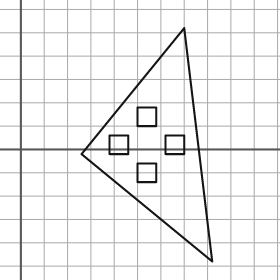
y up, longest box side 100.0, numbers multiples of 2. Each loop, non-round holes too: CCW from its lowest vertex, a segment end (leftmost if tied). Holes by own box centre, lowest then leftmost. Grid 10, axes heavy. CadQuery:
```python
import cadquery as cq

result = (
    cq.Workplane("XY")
    .moveTo(82.0, -48.0)
    .lineTo(70.0, 52.0)
    .lineTo(26.0, -2.0)
    .close()
    .moveTo(50.0, -14.0)
    .lineTo(58.0, -14.0)
    .lineTo(58.0, -6.0)
    .lineTo(50.0, -6.0)
    .close()
    .moveTo(38.0, -2.0)
    .lineTo(46.0, -2.0)
    .lineTo(46.0, 6.0)
    .lineTo(38.0, 6.0)
    .close()
    .moveTo(62.0, -2.0)
    .lineTo(70.0, -2.0)
    .lineTo(70.0, 6.0)
    .lineTo(62.0, 6.0)
    .close()
    .moveTo(50.0, 10.0)
    .lineTo(58.0, 10.0)
    .lineTo(58.0, 18.0)
    .lineTo(50.0, 18.0)
    .close()
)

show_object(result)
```